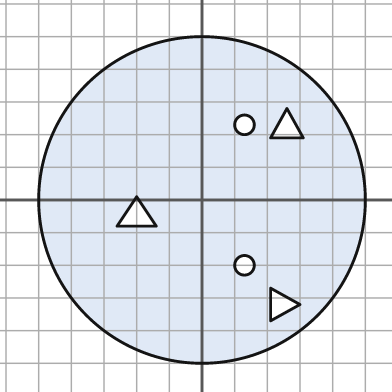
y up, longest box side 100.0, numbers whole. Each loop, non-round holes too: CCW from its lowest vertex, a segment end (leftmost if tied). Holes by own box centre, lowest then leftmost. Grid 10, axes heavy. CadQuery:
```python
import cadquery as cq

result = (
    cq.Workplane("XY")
    .moveTo(0.0, 0.0)
    .circle(50.0)
    .moveTo(21.0, -37.0)
    .lineTo(30.0, -32.0)
    .lineTo(21.0, -27.0)
    .close()
    .moveTo(13.0, -20.0)
    .circle(3.0)
    .moveTo(-26.0, -8.0)
    .lineTo(-14.0, -8.0)
    .lineTo(-20.0, 1.0)
    .close()
    .moveTo(13.0, 23.0)
    .circle(3.0)
    .moveTo(21.0, 19.0)
    .lineTo(31.0, 19.0)
    .lineTo(26.0, 28.0)
    .close()
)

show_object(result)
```